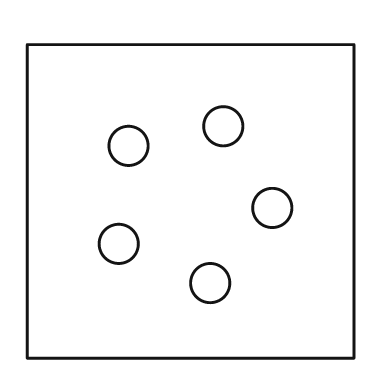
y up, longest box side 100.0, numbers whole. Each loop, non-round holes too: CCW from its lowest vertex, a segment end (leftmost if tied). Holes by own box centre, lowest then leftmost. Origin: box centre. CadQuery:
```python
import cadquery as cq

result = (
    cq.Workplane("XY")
    .moveTo(-50.0, -48.0)
    .lineTo(50.0, -48.0)
    .lineTo(50.0, 48.0)
    .lineTo(-50.0, 48.0)
    .close()
    .moveTo(6.0, -25.0)
    .circle(6.0)
    .moveTo(-22.0, -13.0)
    .circle(6.0)
    .moveTo(25.0, -2.0)
    .circle(6.0)
    .moveTo(-19.0, 17.0)
    .circle(6.0)
    .moveTo(10.0, 23.0)
    .circle(6.0)
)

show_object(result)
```